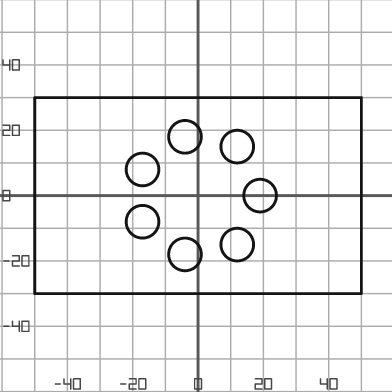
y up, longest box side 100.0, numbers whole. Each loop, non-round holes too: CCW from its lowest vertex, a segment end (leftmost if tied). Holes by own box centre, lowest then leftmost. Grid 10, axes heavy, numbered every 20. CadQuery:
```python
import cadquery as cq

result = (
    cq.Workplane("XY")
    .moveTo(-50.0, -30.0)
    .lineTo(50.0, -30.0)
    .lineTo(50.0, 30.0)
    .lineTo(-50.0, 30.0)
    .close()
    .moveTo(-4.0, -18.0)
    .circle(5.0)
    .moveTo(12.0, -15.0)
    .circle(5.0)
    .moveTo(-17.0, -8.0)
    .circle(5.0)
    .moveTo(19.0, 0.0)
    .circle(5.0)
    .moveTo(-17.0, 8.0)
    .circle(5.0)
    .moveTo(12.0, 15.0)
    .circle(5.0)
    .moveTo(-4.0, 18.0)
    .circle(5.0)
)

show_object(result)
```